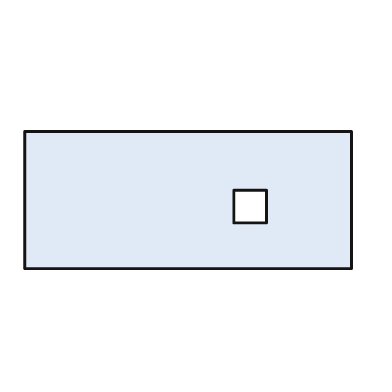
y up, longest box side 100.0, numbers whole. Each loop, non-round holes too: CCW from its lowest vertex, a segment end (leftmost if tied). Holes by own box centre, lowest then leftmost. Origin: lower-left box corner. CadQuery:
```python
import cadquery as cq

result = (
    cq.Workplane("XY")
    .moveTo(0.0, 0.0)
    .lineTo(100.0, 0.0)
    .lineTo(100.0, 42.0)
    .lineTo(0.0, 42.0)
    .close()
    .moveTo(64.0, 14.0)
    .lineTo(74.0, 14.0)
    .lineTo(74.0, 24.0)
    .lineTo(64.0, 24.0)
    .close()
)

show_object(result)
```